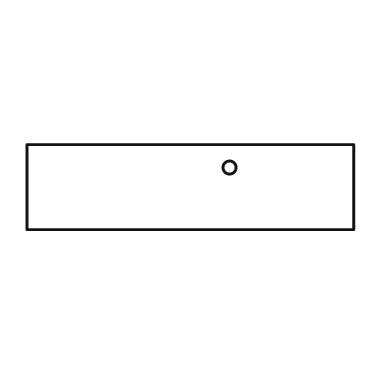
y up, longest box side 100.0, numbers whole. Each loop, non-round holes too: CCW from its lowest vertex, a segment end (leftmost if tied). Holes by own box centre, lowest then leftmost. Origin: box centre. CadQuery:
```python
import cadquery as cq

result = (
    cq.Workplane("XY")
    .moveTo(-50.0, -13.0)
    .lineTo(50.0, -13.0)
    .lineTo(50.0, 13.0)
    .lineTo(-50.0, 13.0)
    .close()
    .moveTo(12.0, 6.0)
    .circle(2.0)
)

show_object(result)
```